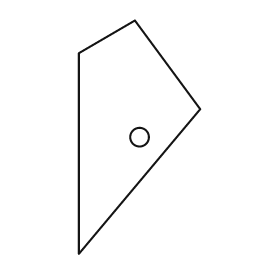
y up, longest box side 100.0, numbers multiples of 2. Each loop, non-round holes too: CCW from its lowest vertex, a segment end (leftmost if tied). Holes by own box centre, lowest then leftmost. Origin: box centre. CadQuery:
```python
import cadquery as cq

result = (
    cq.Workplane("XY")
    .moveTo(-26.0, -50.0)
    .lineTo(26.0, 12.0)
    .lineTo(-2.0, 50.0)
    .lineTo(-26.0, 36.0)
    .close()
    .moveTo(0.0, 0.0)
    .circle(4.0)
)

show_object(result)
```